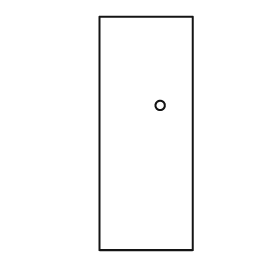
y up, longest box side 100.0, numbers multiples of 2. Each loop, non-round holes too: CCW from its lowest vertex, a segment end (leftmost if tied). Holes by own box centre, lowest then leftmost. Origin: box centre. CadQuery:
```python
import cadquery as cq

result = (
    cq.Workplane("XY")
    .moveTo(-20.0, -50.0)
    .lineTo(20.0, -50.0)
    .lineTo(20.0, 50.0)
    .lineTo(-20.0, 50.0)
    .close()
    .moveTo(6.0, 12.0)
    .circle(2.0)
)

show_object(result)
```